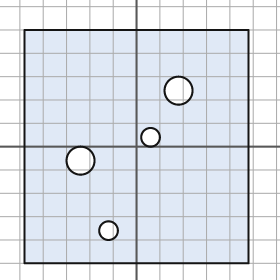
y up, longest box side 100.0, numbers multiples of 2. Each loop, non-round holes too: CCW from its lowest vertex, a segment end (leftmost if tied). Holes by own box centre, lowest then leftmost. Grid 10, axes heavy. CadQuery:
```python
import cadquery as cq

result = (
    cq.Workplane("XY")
    .moveTo(-48.0, -50.0)
    .lineTo(48.0, -50.0)
    .lineTo(48.0, 50.0)
    .lineTo(-48.0, 50.0)
    .close()
    .moveTo(-12.0, -36.0)
    .circle(4.0)
    .moveTo(-24.0, -6.0)
    .circle(6.0)
    .moveTo(6.0, 4.0)
    .circle(4.0)
    .moveTo(18.0, 24.0)
    .circle(6.0)
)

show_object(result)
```